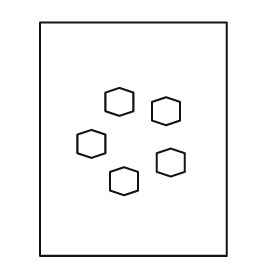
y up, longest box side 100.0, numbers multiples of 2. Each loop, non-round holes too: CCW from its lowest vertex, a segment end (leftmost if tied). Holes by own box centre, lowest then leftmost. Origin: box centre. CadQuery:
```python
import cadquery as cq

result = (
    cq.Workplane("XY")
    .moveTo(-40.0, -50.0)
    .lineTo(40.0, -50.0)
    .lineTo(40.0, 50.0)
    .lineTo(-40.0, 50.0)
    .close()
    .moveTo(-4.0, -24.0)
    .lineTo(2.0, -22.0)
    .lineTo(2.0, -14.0)
    .lineTo(-4.0, -12.0)
    .lineTo(-10.0, -14.0)
    .lineTo(-10.0, -22.0)
    .close()
    .moveTo(16.0, -16.0)
    .lineTo(22.0, -14.0)
    .lineTo(22.0, -6.0)
    .lineTo(16.0, -4.0)
    .lineTo(10.0, -6.0)
    .lineTo(10.0, -14.0)
    .close()
    .moveTo(-18.0, -8.0)
    .lineTo(-12.0, -6.0)
    .lineTo(-12.0, 2.0)
    .lineTo(-18.0, 4.0)
    .lineTo(-24.0, 2.0)
    .lineTo(-24.0, -6.0)
    .close()
    .moveTo(14.0, 6.0)
    .lineTo(20.0, 8.0)
    .lineTo(20.0, 16.0)
    .lineTo(14.0, 18.0)
    .lineTo(8.0, 16.0)
    .lineTo(8.0, 8.0)
    .close()
    .moveTo(-6.0, 10.0)
    .lineTo(0.0, 12.0)
    .lineTo(0.0, 20.0)
    .lineTo(-6.0, 22.0)
    .lineTo(-12.0, 20.0)
    .lineTo(-12.0, 12.0)
    .close()
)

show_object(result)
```